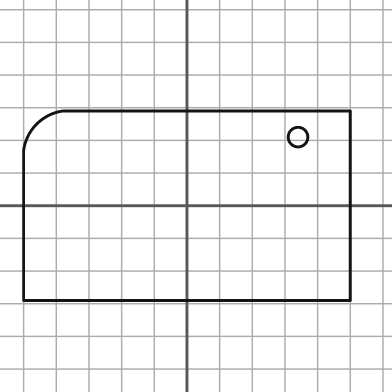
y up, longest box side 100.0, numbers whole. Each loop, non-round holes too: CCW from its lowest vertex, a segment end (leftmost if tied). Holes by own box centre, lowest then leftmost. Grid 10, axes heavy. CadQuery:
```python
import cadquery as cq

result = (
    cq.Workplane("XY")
    .moveTo(-50.0, -29.0)
    .lineTo(50.0, -29.0)
    .lineTo(50.0, 29.0)
    .lineTo(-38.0, 29.0)
    .threePointArc((-46.0, 25.0), (-50.0, 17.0))
    .close()
    .moveTo(34.0, 21.0)
    .circle(3.0)
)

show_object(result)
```